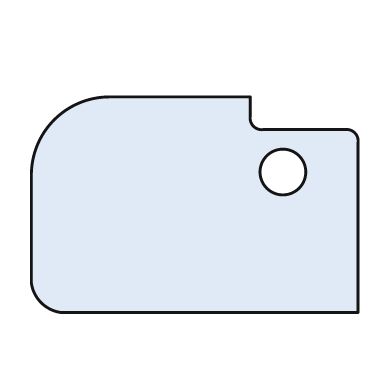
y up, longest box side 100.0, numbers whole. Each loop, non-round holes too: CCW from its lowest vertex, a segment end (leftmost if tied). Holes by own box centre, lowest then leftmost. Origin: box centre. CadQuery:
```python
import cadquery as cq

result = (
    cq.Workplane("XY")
    .moveTo(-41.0, -33.0)
    .lineTo(50.0, -33.0)
    .lineTo(50.0, 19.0)
    .threePointArc((49.0, 22.0), (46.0, 23.0))
    .lineTo(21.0, 23.0)
    .threePointArc((18.0, 24.0), (17.0, 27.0))
    .lineTo(17.0, 33.0)
    .lineTo(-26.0, 33.0)
    .threePointArc((-43.0, 26.0), (-50.0, 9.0))
    .lineTo(-50.0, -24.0)
    .threePointArc((-47.0, -30.0), (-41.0, -33.0))
    .close()
    .moveTo(27.0, 10.0)
    .circle(7.0)
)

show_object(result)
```